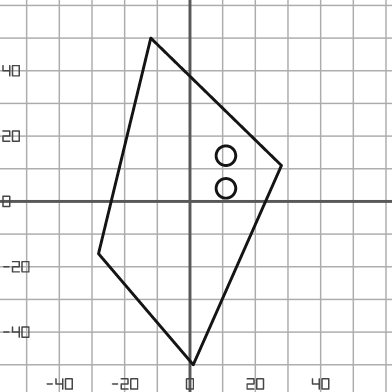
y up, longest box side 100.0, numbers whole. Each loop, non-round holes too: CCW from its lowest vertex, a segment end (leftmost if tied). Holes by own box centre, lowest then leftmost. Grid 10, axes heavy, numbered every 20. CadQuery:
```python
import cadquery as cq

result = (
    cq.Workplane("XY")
    .moveTo(1.0, -50.0)
    .lineTo(28.0, 11.0)
    .lineTo(-12.0, 50.0)
    .lineTo(-28.0, -16.0)
    .close()
    .moveTo(11.0, 4.0)
    .circle(3.0)
    .moveTo(11.0, 14.0)
    .circle(3.0)
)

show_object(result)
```